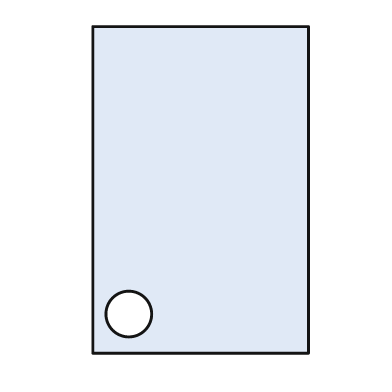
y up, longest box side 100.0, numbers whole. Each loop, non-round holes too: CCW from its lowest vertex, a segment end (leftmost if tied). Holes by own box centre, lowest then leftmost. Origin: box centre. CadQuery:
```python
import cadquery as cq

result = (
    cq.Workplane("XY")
    .moveTo(-33.0, -50.0)
    .lineTo(33.0, -50.0)
    .lineTo(33.0, 50.0)
    .lineTo(-33.0, 50.0)
    .close()
    .moveTo(-22.0, -38.0)
    .circle(7.0)
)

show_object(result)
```